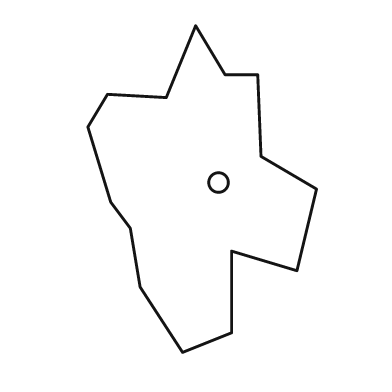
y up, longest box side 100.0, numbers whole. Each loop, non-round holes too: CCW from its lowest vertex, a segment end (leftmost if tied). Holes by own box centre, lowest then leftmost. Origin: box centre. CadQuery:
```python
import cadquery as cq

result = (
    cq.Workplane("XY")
    .moveTo(-6.0, -50.0)
    .lineTo(9.0, -44.0)
    .lineTo(9.0, -19.0)
    .lineTo(29.0, -25.0)
    .lineTo(35.0, 0.0)
    .lineTo(18.0, 10.0)
    .lineTo(17.0, 35.0)
    .lineTo(7.0, 35.0)
    .lineTo(-2.0, 50.0)
    .lineTo(-11.0, 28.0)
    .lineTo(-29.0, 29.0)
    .lineTo(-35.0, 19.0)
    .lineTo(-28.0, -4.0)
    .lineTo(-22.0, -12.0)
    .lineTo(-19.0, -30.0)
    .close()
    .moveTo(5.0, 2.0)
    .circle(3.0)
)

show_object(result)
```